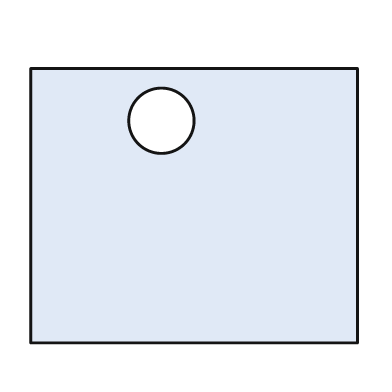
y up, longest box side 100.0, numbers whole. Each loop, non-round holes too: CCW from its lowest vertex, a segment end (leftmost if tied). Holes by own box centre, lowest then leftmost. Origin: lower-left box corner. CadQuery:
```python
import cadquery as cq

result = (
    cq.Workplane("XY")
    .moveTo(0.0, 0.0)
    .lineTo(100.0, 0.0)
    .lineTo(100.0, 84.0)
    .lineTo(0.0, 84.0)
    .close()
    .moveTo(40.0, 68.0)
    .circle(10.0)
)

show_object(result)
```